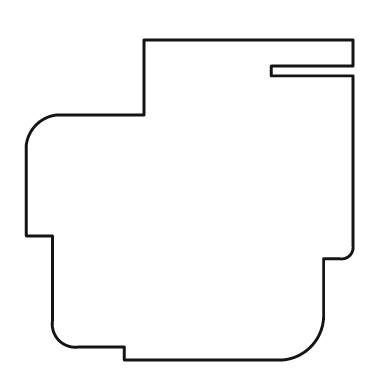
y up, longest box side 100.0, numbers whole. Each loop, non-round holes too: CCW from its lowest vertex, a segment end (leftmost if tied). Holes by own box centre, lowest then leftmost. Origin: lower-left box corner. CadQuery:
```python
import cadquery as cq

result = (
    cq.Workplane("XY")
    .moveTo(30.0, 0.0)
    .lineTo(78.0, 0.0)
    .threePointArc((87.0, 4.0), (91.0, 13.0))
    .lineTo(91.0, 31.0)
    .lineTo(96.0, 31.0)
    .threePointArc((99.0, 32.0), (100.0, 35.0))
    .lineTo(100.0, 87.0)
    .lineTo(75.0, 87.0)
    .lineTo(75.0, 90.0)
    .lineTo(100.0, 90.0)
    .lineTo(100.0, 98.0)
    .lineTo(36.0, 98.0)
    .lineTo(36.0, 75.0)
    .lineTo(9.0, 75.0)
    .threePointArc((3.0, 72.0), (0.0, 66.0))
    .lineTo(0.0, 38.0)
    .lineTo(8.0, 38.0)
    .lineTo(8.0, 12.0)
    .threePointArc((10.0, 6.0), (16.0, 4.0))
    .lineTo(30.0, 4.0)
    .close()
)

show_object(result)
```